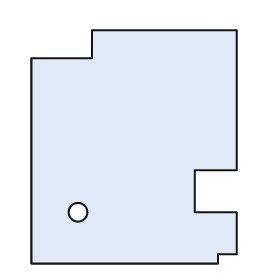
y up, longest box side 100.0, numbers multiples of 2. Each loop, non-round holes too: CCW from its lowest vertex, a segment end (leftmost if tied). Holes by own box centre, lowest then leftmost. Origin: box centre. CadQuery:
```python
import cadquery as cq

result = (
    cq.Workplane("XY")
    .moveTo(-44.0, -50.0)
    .lineTo(36.0, -50.0)
    .lineTo(36.0, -46.0)
    .lineTo(44.0, -46.0)
    .lineTo(44.0, -28.0)
    .lineTo(26.0, -28.0)
    .lineTo(26.0, -10.0)
    .lineTo(44.0, -10.0)
    .lineTo(44.0, 50.0)
    .lineTo(-18.0, 50.0)
    .lineTo(-18.0, 38.0)
    .lineTo(-44.0, 38.0)
    .close()
    .moveTo(-24.0, -28.0)
    .circle(4.0)
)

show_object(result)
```